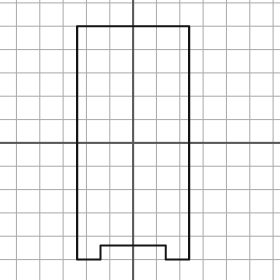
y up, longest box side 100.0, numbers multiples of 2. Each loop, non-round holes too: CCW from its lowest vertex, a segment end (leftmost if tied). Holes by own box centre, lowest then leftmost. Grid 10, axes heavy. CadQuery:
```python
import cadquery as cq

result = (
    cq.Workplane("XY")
    .moveTo(-24.0, -50.0)
    .lineTo(-14.0, -50.0)
    .lineTo(-14.0, -44.0)
    .lineTo(14.0, -44.0)
    .lineTo(14.0, -50.0)
    .lineTo(24.0, -50.0)
    .lineTo(24.0, 50.0)
    .lineTo(-24.0, 50.0)
    .close()
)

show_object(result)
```